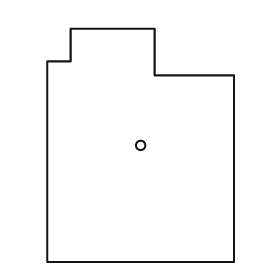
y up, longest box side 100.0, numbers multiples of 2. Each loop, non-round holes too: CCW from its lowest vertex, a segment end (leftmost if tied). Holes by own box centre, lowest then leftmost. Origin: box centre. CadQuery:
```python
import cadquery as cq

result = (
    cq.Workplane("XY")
    .moveTo(-40.0, -50.0)
    .lineTo(40.0, -50.0)
    .lineTo(40.0, 30.0)
    .lineTo(6.0, 30.0)
    .lineTo(6.0, 50.0)
    .lineTo(-30.0, 50.0)
    .lineTo(-30.0, 36.0)
    .lineTo(-40.0, 36.0)
    .close()
    .moveTo(0.0, 0.0)
    .circle(2.0)
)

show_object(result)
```